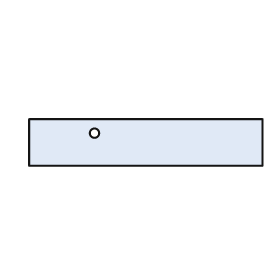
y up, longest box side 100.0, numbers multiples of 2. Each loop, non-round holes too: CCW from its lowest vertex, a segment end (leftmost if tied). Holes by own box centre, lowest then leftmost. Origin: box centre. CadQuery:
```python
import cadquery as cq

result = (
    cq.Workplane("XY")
    .moveTo(-50.0, -10.0)
    .lineTo(50.0, -10.0)
    .lineTo(50.0, 10.0)
    .lineTo(-50.0, 10.0)
    .close()
    .moveTo(-22.0, 4.0)
    .circle(2.0)
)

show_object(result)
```